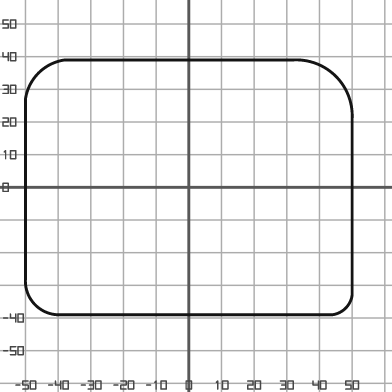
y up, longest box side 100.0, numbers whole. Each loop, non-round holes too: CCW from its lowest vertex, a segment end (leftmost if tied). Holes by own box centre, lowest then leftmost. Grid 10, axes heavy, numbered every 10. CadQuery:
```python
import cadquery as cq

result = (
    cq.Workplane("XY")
    .moveTo(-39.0, -39.0)
    .lineTo(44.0, -39.0)
    .threePointArc((48.0, -37.0), (50.0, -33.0))
    .lineTo(50.0, 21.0)
    .threePointArc((45.0, 34.0), (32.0, 39.0))
    .lineTo(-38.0, 39.0)
    .threePointArc((-46.0, 35.0), (-50.0, 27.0))
    .lineTo(-50.0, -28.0)
    .threePointArc((-47.0, -36.0), (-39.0, -39.0))
    .close()
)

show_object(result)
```